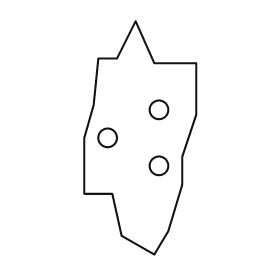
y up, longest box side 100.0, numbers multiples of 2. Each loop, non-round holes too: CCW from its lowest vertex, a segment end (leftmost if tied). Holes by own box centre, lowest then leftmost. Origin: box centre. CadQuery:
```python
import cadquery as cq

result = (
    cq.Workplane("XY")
    .moveTo(6.0, -50.0)
    .lineTo(12.0, -40.0)
    .lineTo(18.0, -20.0)
    .lineTo(18.0, -8.0)
    .lineTo(24.0, 10.0)
    .lineTo(24.0, 32.0)
    .lineTo(6.0, 32.0)
    .lineTo(-2.0, 50.0)
    .lineTo(-10.0, 34.0)
    .lineTo(-18.0, 34.0)
    .lineTo(-20.0, 14.0)
    .lineTo(-24.0, 0.0)
    .lineTo(-24.0, -24.0)
    .lineTo(-12.0, -24.0)
    .lineTo(-8.0, -42.0)
    .close()
    .moveTo(8.0, -12.0)
    .circle(4.0)
    .moveTo(-14.0, 0.0)
    .circle(4.0)
    .moveTo(8.0, 12.0)
    .circle(4.0)
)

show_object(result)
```